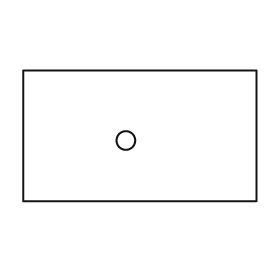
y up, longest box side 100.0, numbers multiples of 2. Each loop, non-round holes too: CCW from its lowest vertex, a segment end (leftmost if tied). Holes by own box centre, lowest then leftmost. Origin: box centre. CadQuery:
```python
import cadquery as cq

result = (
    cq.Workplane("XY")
    .moveTo(-50.0, -28.0)
    .lineTo(50.0, -28.0)
    .lineTo(50.0, 28.0)
    .lineTo(-50.0, 28.0)
    .close()
    .moveTo(-6.0, -2.0)
    .circle(4.0)
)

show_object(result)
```